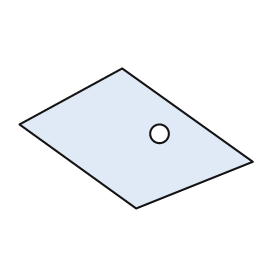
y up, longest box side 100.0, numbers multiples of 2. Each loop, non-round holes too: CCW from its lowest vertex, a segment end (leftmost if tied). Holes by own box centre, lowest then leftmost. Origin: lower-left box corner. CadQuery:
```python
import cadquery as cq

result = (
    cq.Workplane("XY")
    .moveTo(50.0, 0.0)
    .lineTo(100.0, 20.0)
    .lineTo(44.0, 60.0)
    .lineTo(0.0, 36.0)
    .close()
    .moveTo(60.0, 32.0)
    .circle(4.0)
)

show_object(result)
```